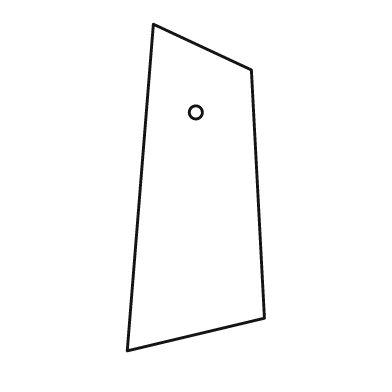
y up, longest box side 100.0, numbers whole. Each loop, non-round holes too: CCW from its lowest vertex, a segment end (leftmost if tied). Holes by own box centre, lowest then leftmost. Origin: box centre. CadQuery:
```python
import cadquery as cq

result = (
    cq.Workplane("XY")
    .moveTo(-21.0, -50.0)
    .lineTo(21.0, -40.0)
    .lineTo(17.0, 36.0)
    .lineTo(-13.0, 50.0)
    .close()
    .moveTo(0.0, 23.0)
    .circle(2.0)
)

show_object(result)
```